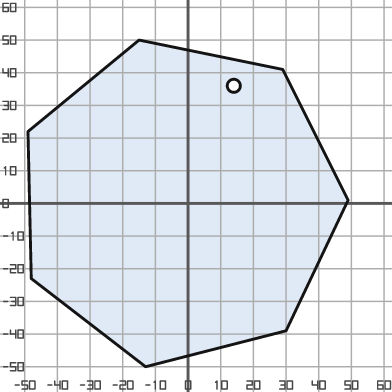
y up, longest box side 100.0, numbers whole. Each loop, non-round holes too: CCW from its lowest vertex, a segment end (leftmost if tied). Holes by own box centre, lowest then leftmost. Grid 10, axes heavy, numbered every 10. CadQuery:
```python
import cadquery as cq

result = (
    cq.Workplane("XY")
    .moveTo(-13.0, -50.0)
    .lineTo(30.0, -39.0)
    .lineTo(49.0, 1.0)
    .lineTo(29.0, 41.0)
    .lineTo(-15.0, 50.0)
    .lineTo(-49.0, 22.0)
    .lineTo(-48.0, -23.0)
    .close()
    .moveTo(14.0, 36.0)
    .circle(2.0)
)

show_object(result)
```